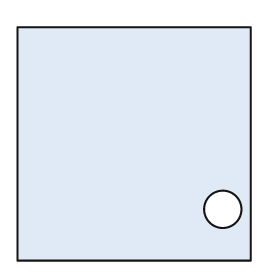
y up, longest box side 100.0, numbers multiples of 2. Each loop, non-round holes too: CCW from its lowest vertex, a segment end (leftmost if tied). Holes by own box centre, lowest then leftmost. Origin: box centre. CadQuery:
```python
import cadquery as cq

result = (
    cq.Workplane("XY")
    .moveTo(-50.0, -50.0)
    .lineTo(50.0, -50.0)
    .lineTo(50.0, 50.0)
    .lineTo(-50.0, 50.0)
    .close()
    .moveTo(38.0, -28.0)
    .circle(8.0)
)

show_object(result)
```